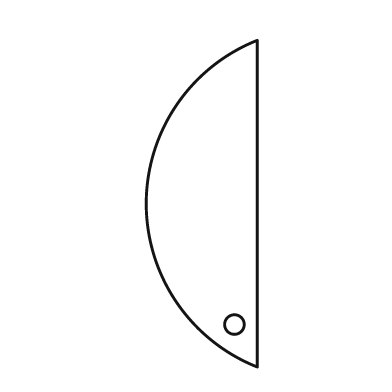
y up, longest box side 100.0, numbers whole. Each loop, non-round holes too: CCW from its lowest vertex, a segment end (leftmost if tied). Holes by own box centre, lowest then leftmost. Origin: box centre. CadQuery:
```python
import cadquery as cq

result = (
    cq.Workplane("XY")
    .moveTo(17.0, -50.0)
    .lineTo(17.0, 50.0)
    .threePointArc((-17.0, 0.0), (17.0, -50.0))
    .close()
    .moveTo(10.0, -37.0)
    .circle(3.0)
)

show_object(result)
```